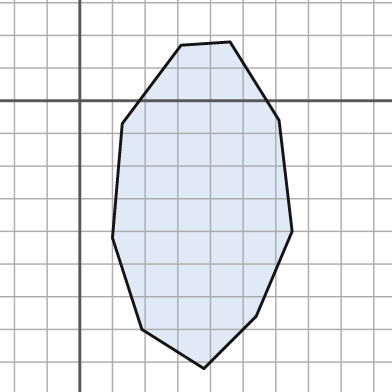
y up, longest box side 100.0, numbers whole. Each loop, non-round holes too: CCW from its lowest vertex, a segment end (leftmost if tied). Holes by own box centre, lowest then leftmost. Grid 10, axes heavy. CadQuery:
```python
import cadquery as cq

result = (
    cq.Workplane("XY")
    .moveTo(38.0, -82.0)
    .lineTo(54.0, -66.0)
    .lineTo(65.0, -40.0)
    .lineTo(61.0, -6.0)
    .lineTo(46.0, 18.0)
    .lineTo(31.0, 17.0)
    .lineTo(13.0, -7.0)
    .lineTo(10.0, -42.0)
    .lineTo(19.0, -70.0)
    .close()
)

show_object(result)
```